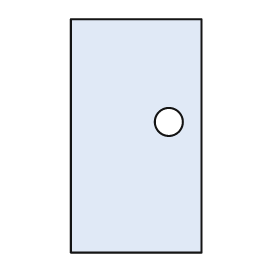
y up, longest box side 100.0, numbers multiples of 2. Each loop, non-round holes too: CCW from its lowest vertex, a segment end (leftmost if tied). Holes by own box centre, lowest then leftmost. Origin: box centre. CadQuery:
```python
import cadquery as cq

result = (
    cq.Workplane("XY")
    .moveTo(-28.0, -50.0)
    .lineTo(28.0, -50.0)
    .lineTo(28.0, 50.0)
    .lineTo(-28.0, 50.0)
    .close()
    .moveTo(14.0, 6.0)
    .circle(6.0)
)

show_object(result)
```